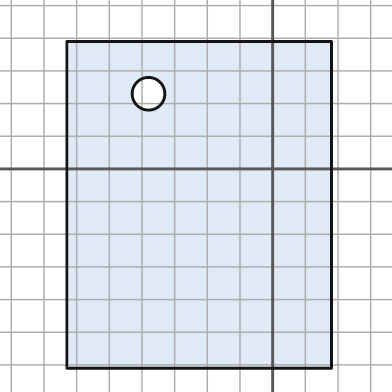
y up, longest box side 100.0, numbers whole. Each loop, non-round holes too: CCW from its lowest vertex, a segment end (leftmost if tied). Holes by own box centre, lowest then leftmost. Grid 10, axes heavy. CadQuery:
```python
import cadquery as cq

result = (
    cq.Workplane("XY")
    .moveTo(-63.0, -61.0)
    .lineTo(18.0, -61.0)
    .lineTo(18.0, 39.0)
    .lineTo(-63.0, 39.0)
    .close()
    .moveTo(-38.0, 23.0)
    .circle(5.0)
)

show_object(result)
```